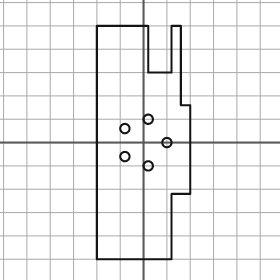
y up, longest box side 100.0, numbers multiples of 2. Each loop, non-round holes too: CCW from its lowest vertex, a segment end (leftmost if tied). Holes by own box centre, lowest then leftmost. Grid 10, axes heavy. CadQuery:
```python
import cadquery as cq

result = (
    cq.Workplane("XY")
    .moveTo(-20.0, -50.0)
    .lineTo(12.0, -50.0)
    .lineTo(12.0, -22.0)
    .lineTo(20.0, -22.0)
    .lineTo(20.0, 16.0)
    .lineTo(16.0, 16.0)
    .lineTo(16.0, 50.0)
    .lineTo(12.0, 50.0)
    .lineTo(12.0, 30.0)
    .lineTo(2.0, 30.0)
    .lineTo(2.0, 50.0)
    .lineTo(-20.0, 50.0)
    .close()
    .moveTo(2.0, -10.0)
    .circle(2.0)
    .moveTo(-8.0, -6.0)
    .circle(2.0)
    .moveTo(10.0, 0.0)
    .circle(2.0)
    .moveTo(-8.0, 6.0)
    .circle(2.0)
    .moveTo(2.0, 10.0)
    .circle(2.0)
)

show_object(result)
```